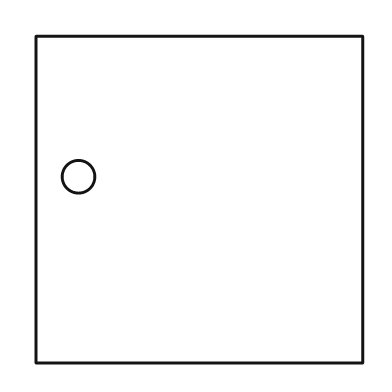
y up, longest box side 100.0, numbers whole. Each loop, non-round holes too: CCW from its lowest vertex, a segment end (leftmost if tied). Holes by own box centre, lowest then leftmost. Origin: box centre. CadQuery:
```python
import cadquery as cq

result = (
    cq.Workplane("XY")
    .moveTo(-50.0, -50.0)
    .lineTo(50.0, -50.0)
    .lineTo(50.0, 50.0)
    .lineTo(-50.0, 50.0)
    .close()
    .moveTo(-37.0, 7.0)
    .circle(5.0)
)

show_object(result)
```